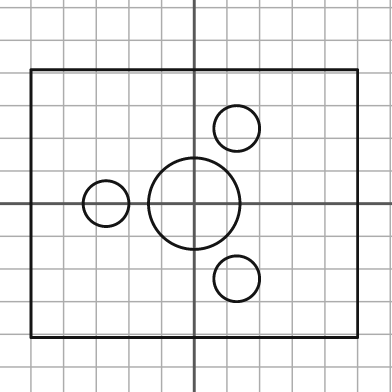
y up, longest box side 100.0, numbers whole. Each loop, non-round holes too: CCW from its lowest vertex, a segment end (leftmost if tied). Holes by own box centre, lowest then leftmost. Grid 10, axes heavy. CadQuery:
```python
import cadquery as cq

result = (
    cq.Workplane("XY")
    .moveTo(-50.0, -41.0)
    .lineTo(50.0, -41.0)
    .lineTo(50.0, 41.0)
    .lineTo(-50.0, 41.0)
    .close()
    .moveTo(13.0, -23.0)
    .circle(7.0)
    .moveTo(-27.0, 0.0)
    .circle(7.0)
    .moveTo(0.0, 0.0)
    .circle(14.0)
    .moveTo(13.0, 23.0)
    .circle(7.0)
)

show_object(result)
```